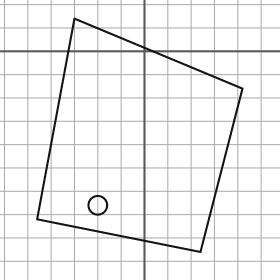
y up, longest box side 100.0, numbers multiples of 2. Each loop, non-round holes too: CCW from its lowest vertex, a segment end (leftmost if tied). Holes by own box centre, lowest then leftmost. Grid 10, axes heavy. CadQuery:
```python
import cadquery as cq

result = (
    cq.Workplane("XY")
    .moveTo(24.0, -86.0)
    .lineTo(42.0, -16.0)
    .lineTo(-30.0, 14.0)
    .lineTo(-46.0, -72.0)
    .close()
    .moveTo(-20.0, -66.0)
    .circle(4.0)
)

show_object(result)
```